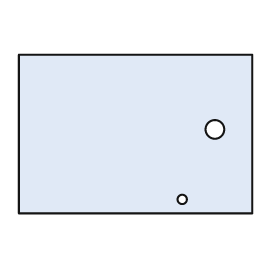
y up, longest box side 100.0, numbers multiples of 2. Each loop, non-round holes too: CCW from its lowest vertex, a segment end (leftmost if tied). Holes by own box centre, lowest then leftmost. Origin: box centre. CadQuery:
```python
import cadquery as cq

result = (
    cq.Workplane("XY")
    .moveTo(-50.0, -34.0)
    .lineTo(50.0, -34.0)
    .lineTo(50.0, 34.0)
    .lineTo(-50.0, 34.0)
    .close()
    .moveTo(20.0, -28.0)
    .circle(2.0)
    .moveTo(34.0, 2.0)
    .circle(4.0)
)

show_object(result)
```